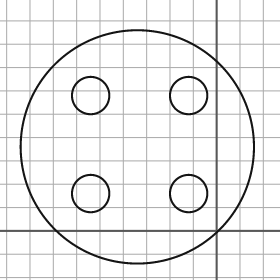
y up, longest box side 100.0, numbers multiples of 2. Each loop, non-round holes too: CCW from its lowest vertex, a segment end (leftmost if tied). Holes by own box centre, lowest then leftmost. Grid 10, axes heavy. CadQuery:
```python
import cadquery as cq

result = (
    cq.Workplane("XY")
    .moveTo(-34.0, 36.0)
    .circle(50.0)
    .moveTo(-54.0, 16.0)
    .circle(8.0)
    .moveTo(-12.0, 16.0)
    .circle(8.0)
    .moveTo(-54.0, 58.0)
    .circle(8.0)
    .moveTo(-12.0, 58.0)
    .circle(8.0)
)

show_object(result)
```